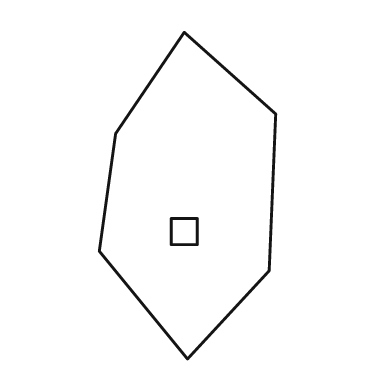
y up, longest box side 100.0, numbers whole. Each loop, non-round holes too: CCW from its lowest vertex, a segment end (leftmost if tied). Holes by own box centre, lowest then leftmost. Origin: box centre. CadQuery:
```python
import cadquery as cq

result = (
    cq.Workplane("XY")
    .moveTo(0.0, -50.0)
    .lineTo(25.0, -23.0)
    .lineTo(27.0, 25.0)
    .lineTo(-1.0, 50.0)
    .lineTo(-22.0, 19.0)
    .lineTo(-27.0, -17.0)
    .close()
    .moveTo(-5.0, -15.0)
    .lineTo(3.0, -15.0)
    .lineTo(3.0, -7.0)
    .lineTo(-5.0, -7.0)
    .close()
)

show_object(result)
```